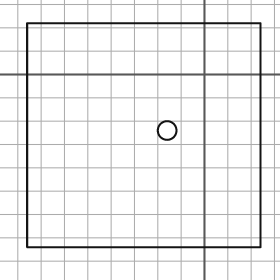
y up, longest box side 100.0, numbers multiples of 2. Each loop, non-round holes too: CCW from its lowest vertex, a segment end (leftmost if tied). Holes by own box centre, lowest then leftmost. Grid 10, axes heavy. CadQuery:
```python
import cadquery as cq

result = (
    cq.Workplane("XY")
    .moveTo(-76.0, -74.0)
    .lineTo(24.0, -74.0)
    .lineTo(24.0, 22.0)
    .lineTo(-76.0, 22.0)
    .close()
    .moveTo(-16.0, -24.0)
    .circle(4.0)
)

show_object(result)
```